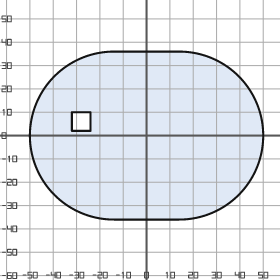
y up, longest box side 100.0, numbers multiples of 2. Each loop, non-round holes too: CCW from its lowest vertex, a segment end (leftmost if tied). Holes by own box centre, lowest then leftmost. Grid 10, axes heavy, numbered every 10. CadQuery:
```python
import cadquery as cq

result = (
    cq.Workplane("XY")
    .moveTo(-14.0, -36.0)
    .lineTo(14.0, -36.0)
    .threePointArc((50.0, 0.0), (14.0, 36.0))
    .lineTo(-14.0, 36.0)
    .threePointArc((-50.0, 0.0), (-14.0, -36.0))
    .close()
    .moveTo(-32.0, 2.0)
    .lineTo(-24.0, 2.0)
    .lineTo(-24.0, 10.0)
    .lineTo(-32.0, 10.0)
    .close()
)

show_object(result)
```